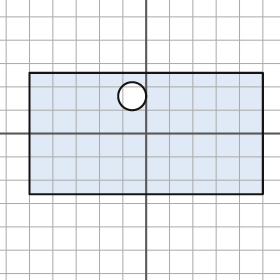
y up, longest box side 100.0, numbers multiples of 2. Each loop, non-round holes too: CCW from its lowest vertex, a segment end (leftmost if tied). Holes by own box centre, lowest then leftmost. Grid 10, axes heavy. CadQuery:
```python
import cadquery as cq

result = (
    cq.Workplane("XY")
    .moveTo(-50.0, -26.0)
    .lineTo(50.0, -26.0)
    .lineTo(50.0, 26.0)
    .lineTo(-50.0, 26.0)
    .close()
    .moveTo(-6.0, 16.0)
    .circle(6.0)
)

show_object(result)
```